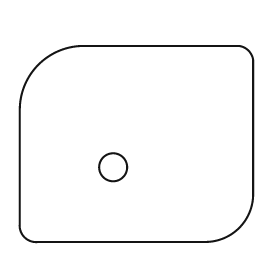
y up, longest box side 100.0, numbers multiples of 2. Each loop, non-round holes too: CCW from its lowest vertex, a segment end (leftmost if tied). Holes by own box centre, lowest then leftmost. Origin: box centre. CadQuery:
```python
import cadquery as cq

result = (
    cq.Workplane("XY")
    .moveTo(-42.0, -42.0)
    .lineTo(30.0, -42.0)
    .threePointArc((44.0, -36.0), (50.0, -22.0))
    .lineTo(50.0, 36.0)
    .threePointArc((48.0, 40.0), (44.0, 42.0))
    .lineTo(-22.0, 42.0)
    .threePointArc((-42.0, 34.0), (-50.0, 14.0))
    .lineTo(-50.0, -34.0)
    .threePointArc((-48.0, -40.0), (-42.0, -42.0))
    .close()
    .moveTo(-10.0, -10.0)
    .circle(6.0)
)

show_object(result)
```